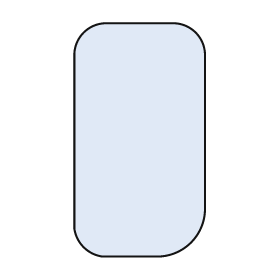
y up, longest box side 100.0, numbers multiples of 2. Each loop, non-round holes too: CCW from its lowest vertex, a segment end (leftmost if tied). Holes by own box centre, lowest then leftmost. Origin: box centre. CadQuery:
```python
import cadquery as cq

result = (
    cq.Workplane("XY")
    .moveTo(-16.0, -50.0)
    .lineTo(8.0, -50.0)
    .threePointArc((22.0, -44.0), (28.0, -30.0))
    .lineTo(28.0, 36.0)
    .threePointArc((24.0, 46.0), (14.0, 50.0))
    .lineTo(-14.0, 50.0)
    .threePointArc((-24.0, 46.0), (-28.0, 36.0))
    .lineTo(-28.0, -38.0)
    .threePointArc((-24.0, -46.0), (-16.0, -50.0))
    .close()
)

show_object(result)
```